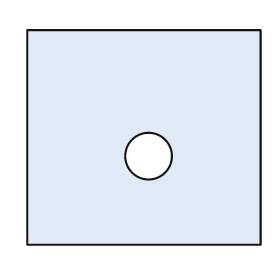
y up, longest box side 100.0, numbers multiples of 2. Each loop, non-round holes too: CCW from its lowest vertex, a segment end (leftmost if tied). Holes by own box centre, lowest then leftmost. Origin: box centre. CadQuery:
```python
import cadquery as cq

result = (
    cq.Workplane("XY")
    .moveTo(-50.0, -46.0)
    .lineTo(50.0, -46.0)
    .lineTo(50.0, 46.0)
    .lineTo(-50.0, 46.0)
    .close()
    .moveTo(2.0, -8.0)
    .circle(10.0)
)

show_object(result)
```